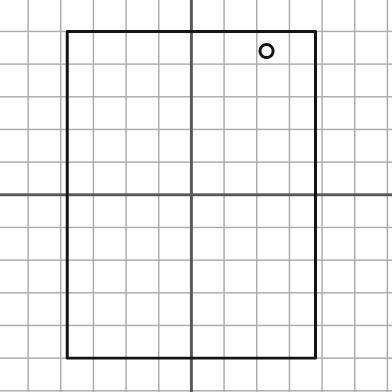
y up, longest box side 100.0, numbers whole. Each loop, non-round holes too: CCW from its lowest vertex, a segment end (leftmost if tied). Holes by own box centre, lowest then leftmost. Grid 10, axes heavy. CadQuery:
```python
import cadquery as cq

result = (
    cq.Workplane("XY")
    .moveTo(-38.0, -50.0)
    .lineTo(38.0, -50.0)
    .lineTo(38.0, 50.0)
    .lineTo(-38.0, 50.0)
    .close()
    .moveTo(23.0, 44.0)
    .circle(2.0)
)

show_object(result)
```